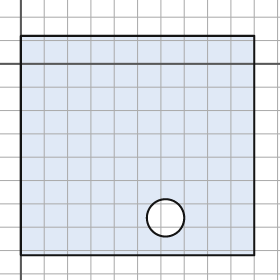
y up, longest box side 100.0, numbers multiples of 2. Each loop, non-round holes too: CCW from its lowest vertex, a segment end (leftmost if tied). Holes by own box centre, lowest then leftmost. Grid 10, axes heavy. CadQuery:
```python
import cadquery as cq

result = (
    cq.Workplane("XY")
    .moveTo(0.0, -82.0)
    .lineTo(100.0, -82.0)
    .lineTo(100.0, 12.0)
    .lineTo(0.0, 12.0)
    .close()
    .moveTo(62.0, -66.0)
    .circle(8.0)
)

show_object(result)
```